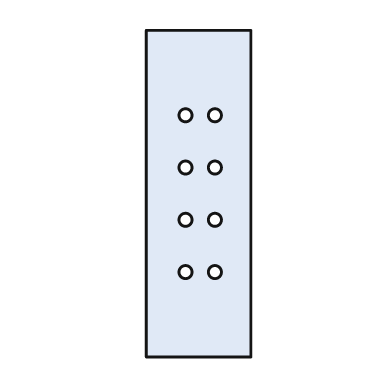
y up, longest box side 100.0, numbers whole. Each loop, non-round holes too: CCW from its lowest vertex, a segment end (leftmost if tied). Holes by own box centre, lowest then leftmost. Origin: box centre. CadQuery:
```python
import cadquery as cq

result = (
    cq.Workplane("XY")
    .moveTo(-16.0, -50.0)
    .lineTo(16.0, -50.0)
    .lineTo(16.0, 50.0)
    .lineTo(-16.0, 50.0)
    .close()
    .moveTo(-4.0, -24.0)
    .circle(2.0)
    .moveTo(5.0, -24.0)
    .circle(2.0)
    .moveTo(-4.0, -8.0)
    .circle(2.0)
    .moveTo(5.0, -8.0)
    .circle(2.0)
    .moveTo(-4.0, 8.0)
    .circle(2.0)
    .moveTo(5.0, 8.0)
    .circle(2.0)
    .moveTo(-4.0, 24.0)
    .circle(2.0)
    .moveTo(5.0, 24.0)
    .circle(2.0)
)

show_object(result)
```